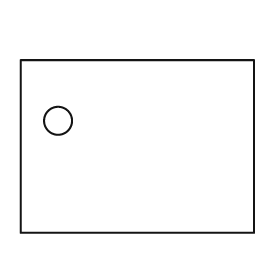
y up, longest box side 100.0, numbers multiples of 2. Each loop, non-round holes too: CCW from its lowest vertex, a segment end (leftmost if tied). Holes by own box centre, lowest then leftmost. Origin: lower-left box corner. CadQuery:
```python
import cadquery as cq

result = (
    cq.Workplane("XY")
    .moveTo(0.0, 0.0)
    .lineTo(100.0, 0.0)
    .lineTo(100.0, 74.0)
    .lineTo(0.0, 74.0)
    .close()
    .moveTo(16.0, 48.0)
    .circle(6.0)
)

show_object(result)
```